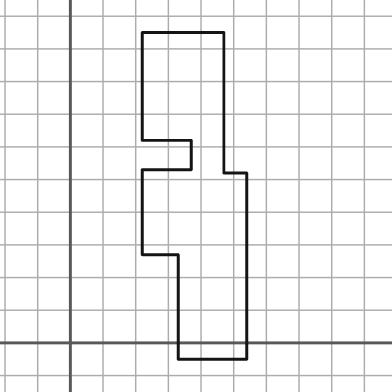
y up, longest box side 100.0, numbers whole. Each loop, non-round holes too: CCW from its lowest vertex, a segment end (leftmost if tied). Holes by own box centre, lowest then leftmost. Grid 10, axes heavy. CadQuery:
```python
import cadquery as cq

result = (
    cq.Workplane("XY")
    .moveTo(33.0, -5.0)
    .lineTo(54.0, -5.0)
    .lineTo(54.0, 52.0)
    .lineTo(47.0, 52.0)
    .lineTo(47.0, 95.0)
    .lineTo(22.0, 95.0)
    .lineTo(22.0, 62.0)
    .lineTo(37.0, 62.0)
    .lineTo(37.0, 53.0)
    .lineTo(22.0, 53.0)
    .lineTo(22.0, 27.0)
    .lineTo(33.0, 27.0)
    .close()
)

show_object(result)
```